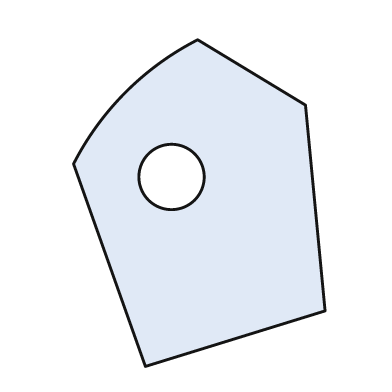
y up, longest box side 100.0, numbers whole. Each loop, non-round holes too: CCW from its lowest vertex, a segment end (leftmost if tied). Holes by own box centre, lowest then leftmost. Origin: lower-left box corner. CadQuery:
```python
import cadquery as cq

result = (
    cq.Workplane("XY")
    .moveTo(22.0, 0.0)
    .lineTo(77.0, 17.0)
    .lineTo(71.0, 80.0)
    .lineTo(38.0, 100.0)
    .threePointArc((16.0, 84.0), (0.0, 62.0))
    .close()
    .moveTo(30.0, 58.0)
    .circle(10.0)
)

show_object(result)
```